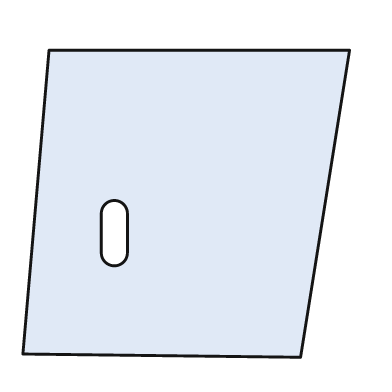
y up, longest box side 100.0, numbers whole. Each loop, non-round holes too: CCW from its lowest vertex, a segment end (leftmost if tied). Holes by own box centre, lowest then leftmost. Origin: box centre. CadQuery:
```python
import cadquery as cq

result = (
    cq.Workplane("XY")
    .moveTo(35.0, -47.0)
    .lineTo(50.0, 47.0)
    .lineTo(-42.0, 47.0)
    .lineTo(-50.0, -46.0)
    .close()
    .moveTo(-26.0, -15.0)
    .threePointArc((-22.0, -19.0), (-18.0, -15.0))
    .lineTo(-18.0, -3.0)
    .threePointArc((-22.0, 1.0), (-26.0, -3.0))
    .close()
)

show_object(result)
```